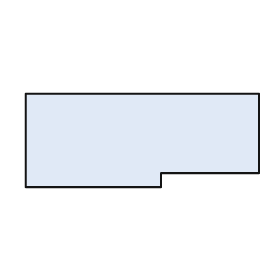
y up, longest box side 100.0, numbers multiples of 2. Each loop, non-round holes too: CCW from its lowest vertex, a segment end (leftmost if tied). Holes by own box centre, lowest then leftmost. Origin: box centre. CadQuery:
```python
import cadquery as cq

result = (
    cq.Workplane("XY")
    .moveTo(-50.0, -20.0)
    .lineTo(8.0, -20.0)
    .lineTo(8.0, -14.0)
    .lineTo(50.0, -14.0)
    .lineTo(50.0, 20.0)
    .lineTo(-50.0, 20.0)
    .close()
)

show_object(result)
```